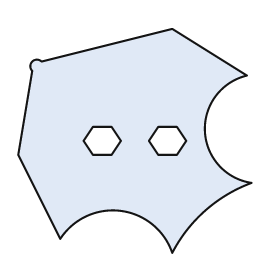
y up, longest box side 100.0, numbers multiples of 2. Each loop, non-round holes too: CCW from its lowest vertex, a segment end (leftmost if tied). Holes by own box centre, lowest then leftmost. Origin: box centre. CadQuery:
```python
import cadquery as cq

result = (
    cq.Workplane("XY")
    .moveTo(16.0, -48.0)
    .threePointArc((30.0, -30.0), (50.0, -18.0))
    .threePointArc((30.0, 4.0), (48.0, 28.0))
    .lineTo(16.0, 48.0)
    .lineTo(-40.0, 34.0)
    .threePointArc((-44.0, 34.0), (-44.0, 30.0))
    .lineTo(-50.0, -6.0)
    .lineTo(-32.0, -42.0)
    .threePointArc((-6.0, -30.0), (16.0, -48.0))
    .close()
    .moveTo(-18.0, -6.0)
    .lineTo(-10.0, -6.0)
    .lineTo(-6.0, 0.0)
    .lineTo(-10.0, 6.0)
    .lineTo(-18.0, 6.0)
    .lineTo(-22.0, 0.0)
    .close()
    .moveTo(10.0, -6.0)
    .lineTo(18.0, -6.0)
    .lineTo(22.0, 0.0)
    .lineTo(18.0, 6.0)
    .lineTo(10.0, 6.0)
    .lineTo(6.0, 0.0)
    .close()
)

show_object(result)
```